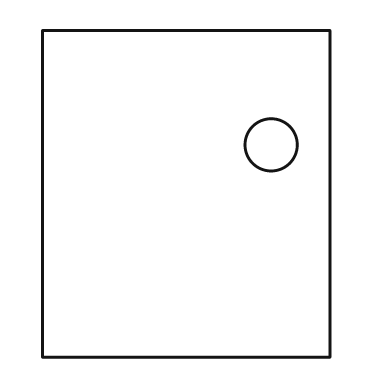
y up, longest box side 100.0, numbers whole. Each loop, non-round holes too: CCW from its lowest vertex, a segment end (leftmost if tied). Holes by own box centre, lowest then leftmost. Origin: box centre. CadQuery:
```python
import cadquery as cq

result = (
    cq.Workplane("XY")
    .moveTo(-44.0, -50.0)
    .lineTo(44.0, -50.0)
    .lineTo(44.0, 50.0)
    .lineTo(-44.0, 50.0)
    .close()
    .moveTo(26.0, 15.0)
    .circle(8.0)
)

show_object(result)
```